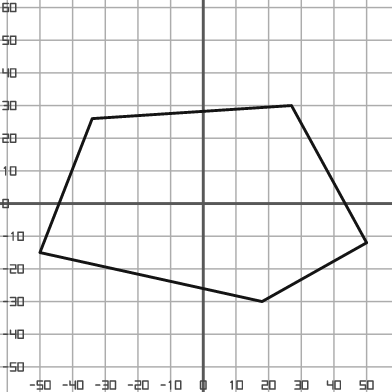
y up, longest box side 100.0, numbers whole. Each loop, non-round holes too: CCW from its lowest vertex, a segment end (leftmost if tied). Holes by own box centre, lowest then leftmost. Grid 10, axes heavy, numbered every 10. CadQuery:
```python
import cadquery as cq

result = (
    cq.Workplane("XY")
    .moveTo(18.0, -30.0)
    .lineTo(50.0, -12.0)
    .lineTo(27.0, 30.0)
    .lineTo(-34.0, 26.0)
    .lineTo(-50.0, -15.0)
    .close()
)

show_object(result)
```